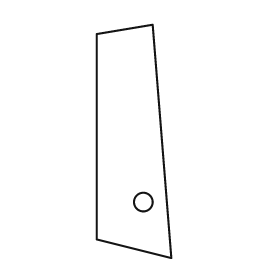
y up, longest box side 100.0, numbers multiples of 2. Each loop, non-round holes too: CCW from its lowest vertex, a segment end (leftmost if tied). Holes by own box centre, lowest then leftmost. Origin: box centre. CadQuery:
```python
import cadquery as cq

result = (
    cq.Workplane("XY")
    .moveTo(16.0, -50.0)
    .lineTo(8.0, 50.0)
    .lineTo(-16.0, 46.0)
    .lineTo(-16.0, -42.0)
    .close()
    .moveTo(4.0, -26.0)
    .circle(4.0)
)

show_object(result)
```